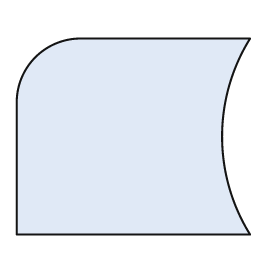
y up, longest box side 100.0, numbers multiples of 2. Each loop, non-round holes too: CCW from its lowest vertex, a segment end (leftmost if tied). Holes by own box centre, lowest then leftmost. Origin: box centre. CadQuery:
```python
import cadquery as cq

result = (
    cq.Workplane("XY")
    .moveTo(-50.0, -42.0)
    .lineTo(50.0, -42.0)
    .threePointArc((38.0, 0.0), (50.0, 42.0))
    .lineTo(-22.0, 42.0)
    .threePointArc((-42.0, 34.0), (-50.0, 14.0))
    .close()
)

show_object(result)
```